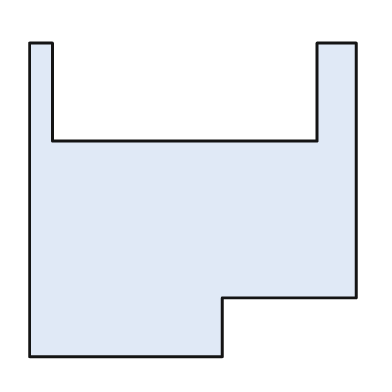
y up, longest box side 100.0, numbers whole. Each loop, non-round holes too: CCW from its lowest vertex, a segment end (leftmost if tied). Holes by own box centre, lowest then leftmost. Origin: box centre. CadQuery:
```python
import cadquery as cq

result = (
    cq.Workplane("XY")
    .moveTo(-50.0, -48.0)
    .lineTo(9.0, -48.0)
    .lineTo(9.0, -30.0)
    .lineTo(50.0, -30.0)
    .lineTo(50.0, 48.0)
    .lineTo(38.0, 48.0)
    .lineTo(38.0, 18.0)
    .lineTo(-43.0, 18.0)
    .lineTo(-43.0, 48.0)
    .lineTo(-50.0, 48.0)
    .close()
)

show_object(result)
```